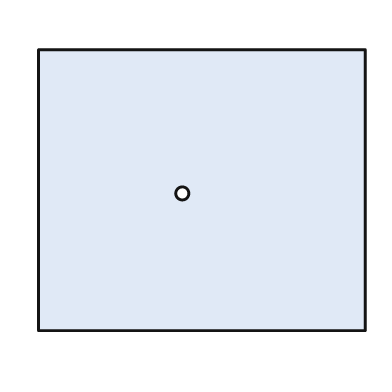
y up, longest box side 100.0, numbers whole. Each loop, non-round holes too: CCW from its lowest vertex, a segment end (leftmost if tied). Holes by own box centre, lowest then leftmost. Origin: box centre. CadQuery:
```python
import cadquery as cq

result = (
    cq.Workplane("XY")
    .moveTo(-50.0, -43.0)
    .lineTo(50.0, -43.0)
    .lineTo(50.0, 43.0)
    .lineTo(-50.0, 43.0)
    .close()
    .moveTo(-6.0, -1.0)
    .circle(2.0)
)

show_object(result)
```